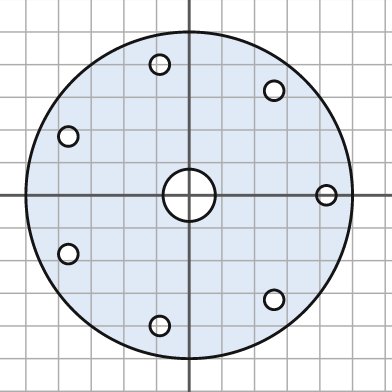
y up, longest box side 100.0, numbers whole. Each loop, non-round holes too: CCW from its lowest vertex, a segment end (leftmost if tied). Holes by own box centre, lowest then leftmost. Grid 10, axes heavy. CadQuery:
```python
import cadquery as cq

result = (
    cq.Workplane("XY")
    .moveTo(0.0, 0.0)
    .circle(50.0)
    .moveTo(-9.0, -40.0)
    .circle(3.0)
    .moveTo(26.0, -32.0)
    .circle(3.0)
    .moveTo(-37.0, -18.0)
    .circle(3.0)
    .moveTo(0.0, 0.0)
    .circle(8.0)
    .moveTo(42.0, 0.0)
    .circle(3.0)
    .moveTo(-37.0, 18.0)
    .circle(3.0)
    .moveTo(26.0, 32.0)
    .circle(3.0)
    .moveTo(-9.0, 40.0)
    .circle(3.0)
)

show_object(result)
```